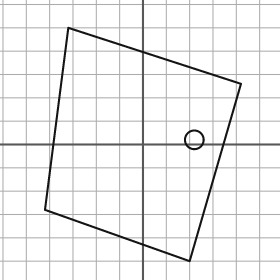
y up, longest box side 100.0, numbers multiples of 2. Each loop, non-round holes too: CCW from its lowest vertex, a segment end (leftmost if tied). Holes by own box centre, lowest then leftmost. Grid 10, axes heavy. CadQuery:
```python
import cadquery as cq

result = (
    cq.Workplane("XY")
    .moveTo(20.0, -50.0)
    .lineTo(42.0, 26.0)
    .lineTo(-32.0, 50.0)
    .lineTo(-42.0, -28.0)
    .close()
    .moveTo(22.0, 2.0)
    .circle(4.0)
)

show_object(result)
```